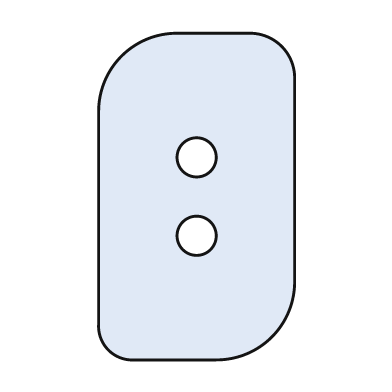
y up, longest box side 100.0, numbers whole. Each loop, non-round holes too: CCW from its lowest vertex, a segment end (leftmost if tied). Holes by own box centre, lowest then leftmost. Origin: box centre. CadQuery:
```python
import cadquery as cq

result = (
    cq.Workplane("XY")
    .moveTo(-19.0, -50.0)
    .lineTo(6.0, -50.0)
    .threePointArc((23.0, -43.0), (30.0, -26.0))
    .lineTo(30.0, 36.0)
    .threePointArc((26.0, 46.0), (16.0, 50.0))
    .lineTo(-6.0, 50.0)
    .threePointArc((-23.0, 43.0), (-30.0, 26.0))
    .lineTo(-30.0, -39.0)
    .threePointArc((-27.0, -47.0), (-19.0, -50.0))
    .close()
    .moveTo(0.0, -12.0)
    .circle(6.0)
    .moveTo(0.0, 12.0)
    .circle(6.0)
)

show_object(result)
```